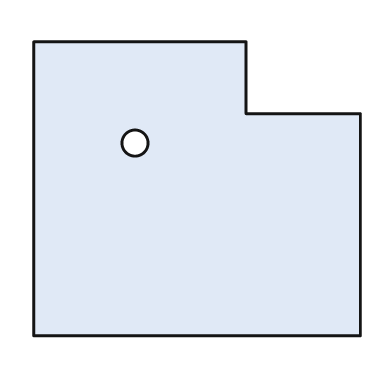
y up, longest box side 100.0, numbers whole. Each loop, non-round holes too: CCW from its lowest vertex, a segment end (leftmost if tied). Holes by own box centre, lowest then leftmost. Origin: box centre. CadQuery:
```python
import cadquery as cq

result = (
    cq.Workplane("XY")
    .moveTo(-50.0, -45.0)
    .lineTo(50.0, -45.0)
    .lineTo(50.0, 23.0)
    .lineTo(15.0, 23.0)
    .lineTo(15.0, 45.0)
    .lineTo(-50.0, 45.0)
    .close()
    .moveTo(-19.0, 14.0)
    .circle(4.0)
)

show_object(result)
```